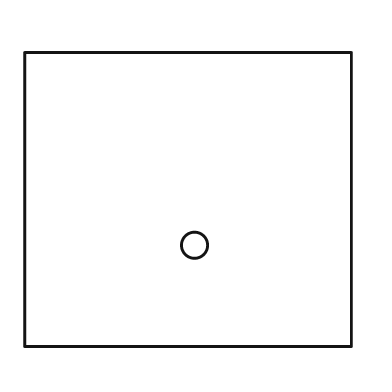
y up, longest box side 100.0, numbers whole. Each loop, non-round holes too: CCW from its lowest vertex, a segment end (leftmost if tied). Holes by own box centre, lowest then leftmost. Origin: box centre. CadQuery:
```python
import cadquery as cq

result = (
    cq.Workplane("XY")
    .moveTo(-50.0, -45.0)
    .lineTo(50.0, -45.0)
    .lineTo(50.0, 45.0)
    .lineTo(-50.0, 45.0)
    .close()
    .moveTo(2.0, -14.0)
    .circle(4.0)
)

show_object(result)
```